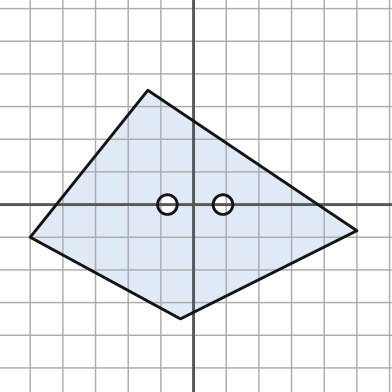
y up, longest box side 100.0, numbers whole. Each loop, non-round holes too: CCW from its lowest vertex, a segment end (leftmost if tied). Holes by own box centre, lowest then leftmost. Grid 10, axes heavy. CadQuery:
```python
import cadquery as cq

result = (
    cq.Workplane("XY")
    .moveTo(-4.0, -35.0)
    .lineTo(50.0, -8.0)
    .lineTo(-14.0, 35.0)
    .lineTo(-50.0, -10.0)
    .close()
    .moveTo(-8.0, 0.0)
    .circle(3.0)
    .moveTo(9.0, 0.0)
    .circle(3.0)
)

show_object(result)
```